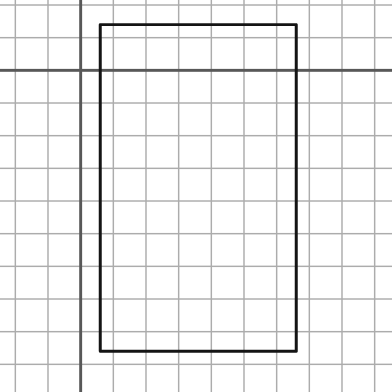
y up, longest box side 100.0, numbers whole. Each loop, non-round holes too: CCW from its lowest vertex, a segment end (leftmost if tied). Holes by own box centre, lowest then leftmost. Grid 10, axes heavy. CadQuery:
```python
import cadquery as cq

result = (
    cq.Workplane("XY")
    .moveTo(6.0, -86.0)
    .lineTo(66.0, -86.0)
    .lineTo(66.0, 14.0)
    .lineTo(6.0, 14.0)
    .close()
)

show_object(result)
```